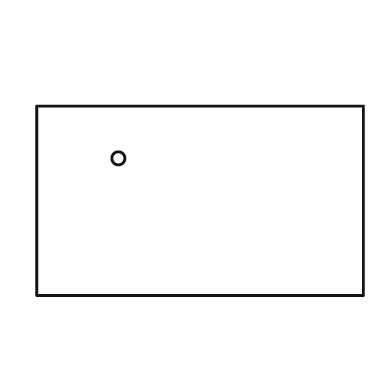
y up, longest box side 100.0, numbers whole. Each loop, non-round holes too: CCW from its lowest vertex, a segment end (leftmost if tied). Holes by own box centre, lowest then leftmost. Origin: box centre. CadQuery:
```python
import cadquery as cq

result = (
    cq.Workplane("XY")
    .moveTo(-50.0, -29.0)
    .lineTo(50.0, -29.0)
    .lineTo(50.0, 29.0)
    .lineTo(-50.0, 29.0)
    .close()
    .moveTo(-25.0, 13.0)
    .circle(2.0)
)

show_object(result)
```